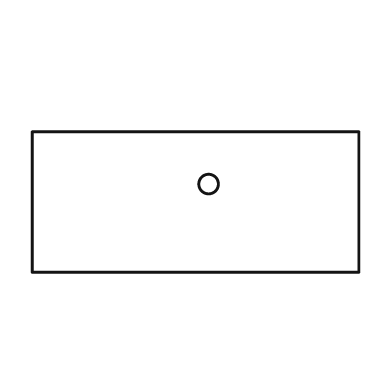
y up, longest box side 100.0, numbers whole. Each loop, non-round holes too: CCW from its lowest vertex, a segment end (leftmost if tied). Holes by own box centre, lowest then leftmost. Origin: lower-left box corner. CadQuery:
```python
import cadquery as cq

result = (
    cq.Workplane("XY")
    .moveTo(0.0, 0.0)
    .lineTo(100.0, 0.0)
    .lineTo(100.0, 43.0)
    .lineTo(0.0, 43.0)
    .close()
    .moveTo(54.0, 27.0)
    .circle(3.0)
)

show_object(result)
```